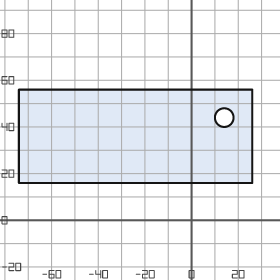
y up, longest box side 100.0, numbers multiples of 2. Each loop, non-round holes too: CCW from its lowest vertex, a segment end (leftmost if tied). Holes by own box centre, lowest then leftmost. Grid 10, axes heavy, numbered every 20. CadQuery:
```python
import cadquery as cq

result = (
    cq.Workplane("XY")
    .moveTo(-74.0, 16.0)
    .lineTo(26.0, 16.0)
    .lineTo(26.0, 56.0)
    .lineTo(-74.0, 56.0)
    .close()
    .moveTo(14.0, 44.0)
    .circle(4.0)
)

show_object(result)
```